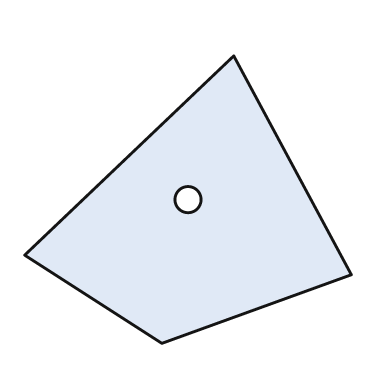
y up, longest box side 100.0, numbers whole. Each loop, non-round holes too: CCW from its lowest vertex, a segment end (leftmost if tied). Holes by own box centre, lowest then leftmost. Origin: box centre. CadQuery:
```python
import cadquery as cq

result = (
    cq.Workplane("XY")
    .moveTo(-8.0, -44.0)
    .lineTo(50.0, -23.0)
    .lineTo(14.0, 44.0)
    .lineTo(-50.0, -17.0)
    .close()
    .moveTo(0.0, 0.0)
    .circle(4.0)
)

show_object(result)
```